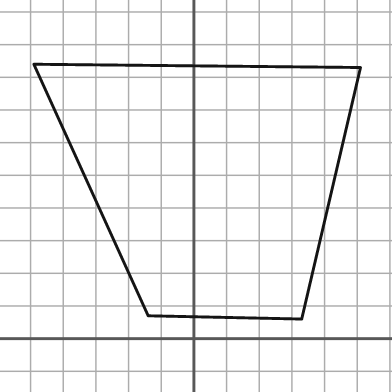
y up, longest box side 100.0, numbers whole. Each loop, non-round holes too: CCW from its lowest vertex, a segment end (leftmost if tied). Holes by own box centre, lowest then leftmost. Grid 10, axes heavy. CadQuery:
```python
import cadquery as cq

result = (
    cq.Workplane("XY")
    .moveTo(33.0, 6.0)
    .lineTo(51.0, 83.0)
    .lineTo(-49.0, 84.0)
    .lineTo(-14.0, 7.0)
    .close()
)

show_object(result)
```